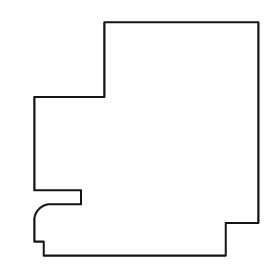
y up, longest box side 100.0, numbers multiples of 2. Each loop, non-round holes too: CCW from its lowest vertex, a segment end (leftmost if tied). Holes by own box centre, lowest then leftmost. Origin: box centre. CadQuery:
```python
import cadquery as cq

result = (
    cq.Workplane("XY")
    .moveTo(-44.0, -50.0)
    .lineTo(34.0, -50.0)
    .lineTo(34.0, -36.0)
    .lineTo(48.0, -36.0)
    .lineTo(48.0, 50.0)
    .lineTo(-18.0, 50.0)
    .lineTo(-18.0, 18.0)
    .lineTo(-48.0, 18.0)
    .lineTo(-48.0, -22.0)
    .lineTo(-28.0, -22.0)
    .lineTo(-28.0, -28.0)
    .lineTo(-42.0, -28.0)
    .threePointArc((-46.0, -30.0), (-48.0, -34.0))
    .lineTo(-48.0, -44.0)
    .lineTo(-44.0, -44.0)
    .close()
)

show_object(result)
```